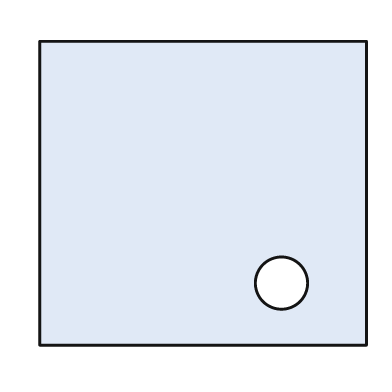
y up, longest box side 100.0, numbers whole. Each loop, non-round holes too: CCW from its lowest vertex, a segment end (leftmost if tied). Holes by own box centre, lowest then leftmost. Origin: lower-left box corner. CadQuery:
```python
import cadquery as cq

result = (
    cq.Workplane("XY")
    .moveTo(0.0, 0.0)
    .lineTo(100.0, 0.0)
    .lineTo(100.0, 93.0)
    .lineTo(0.0, 93.0)
    .close()
    .moveTo(74.0, 19.0)
    .circle(8.0)
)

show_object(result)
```